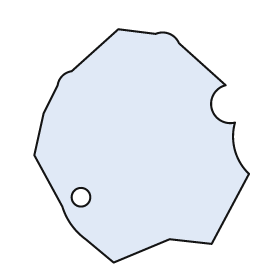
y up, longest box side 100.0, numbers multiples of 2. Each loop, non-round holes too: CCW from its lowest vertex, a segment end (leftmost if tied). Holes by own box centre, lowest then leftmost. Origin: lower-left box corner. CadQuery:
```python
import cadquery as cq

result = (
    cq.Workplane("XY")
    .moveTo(34.0, 0.0)
    .lineTo(58.0, 10.0)
    .lineTo(76.0, 8.0)
    .lineTo(92.0, 38.0)
    .threePointArc((86.0, 48.0), (86.0, 60.0))
    .threePointArc((76.0, 66.0), (82.0, 76.0))
    .lineTo(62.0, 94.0)
    .threePointArc((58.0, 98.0), (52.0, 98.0))
    .lineTo(36.0, 100.0)
    .lineTo(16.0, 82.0)
    .threePointArc((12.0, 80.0), (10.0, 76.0))
    .lineTo(4.0, 64.0)
    .lineTo(0.0, 46.0)
    .lineTo(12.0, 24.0)
    .threePointArc((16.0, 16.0), (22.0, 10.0))
    .close()
    .moveTo(20.0, 28.0)
    .circle(4.0)
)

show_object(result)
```